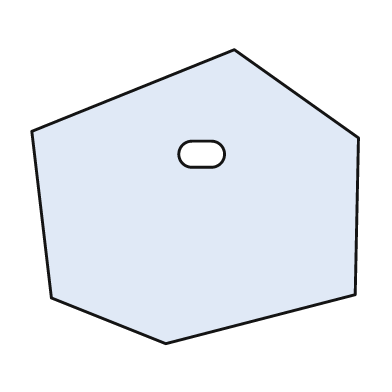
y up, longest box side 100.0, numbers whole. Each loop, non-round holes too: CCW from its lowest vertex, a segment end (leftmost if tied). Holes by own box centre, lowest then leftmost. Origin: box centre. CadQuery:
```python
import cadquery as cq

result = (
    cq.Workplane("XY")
    .moveTo(-9.0, -45.0)
    .lineTo(49.0, -30.0)
    .lineTo(50.0, 18.0)
    .lineTo(12.0, 45.0)
    .lineTo(-50.0, 20.0)
    .lineTo(-44.0, -31.0)
    .close()
    .moveTo(-1.0, 9.0)
    .lineTo(5.0, 9.0)
    .threePointArc((9.0, 13.0), (5.0, 17.0))
    .lineTo(-1.0, 17.0)
    .threePointArc((-5.0, 13.0), (-1.0, 9.0))
    .close()
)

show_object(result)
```